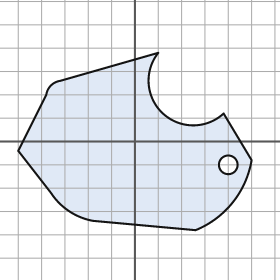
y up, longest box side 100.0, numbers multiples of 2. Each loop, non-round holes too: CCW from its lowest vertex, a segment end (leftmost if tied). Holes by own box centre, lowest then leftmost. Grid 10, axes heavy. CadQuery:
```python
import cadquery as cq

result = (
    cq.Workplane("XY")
    .moveTo(26.0, -38.0)
    .threePointArc((42.0, -26.0), (50.0, -8.0))
    .lineTo(38.0, 12.0)
    .threePointArc((12.0, 12.0), (10.0, 38.0))
    .lineTo(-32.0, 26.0)
    .threePointArc((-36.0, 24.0), (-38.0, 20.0))
    .lineTo(-50.0, -4.0)
    .lineTo(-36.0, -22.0)
    .threePointArc((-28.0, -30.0), (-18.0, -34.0))
    .close()
    .moveTo(40.0, -10.0)
    .circle(4.0)
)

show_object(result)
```